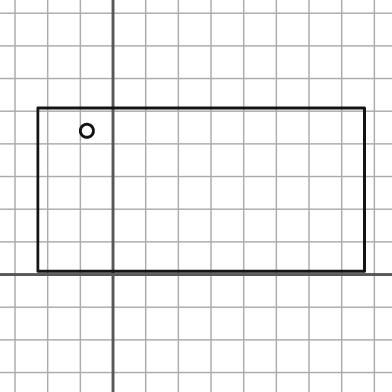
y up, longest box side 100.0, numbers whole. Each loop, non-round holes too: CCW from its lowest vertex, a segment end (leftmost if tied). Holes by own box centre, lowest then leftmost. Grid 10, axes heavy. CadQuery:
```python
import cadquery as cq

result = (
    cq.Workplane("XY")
    .moveTo(-23.0, 1.0)
    .lineTo(77.0, 1.0)
    .lineTo(77.0, 51.0)
    .lineTo(-23.0, 51.0)
    .close()
    .moveTo(-8.0, 44.0)
    .circle(2.0)
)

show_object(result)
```